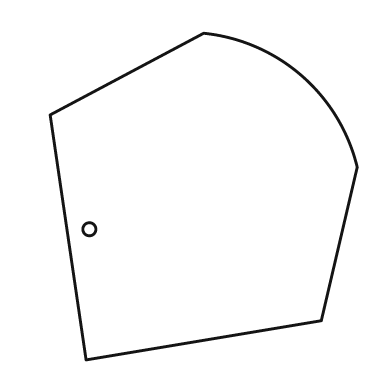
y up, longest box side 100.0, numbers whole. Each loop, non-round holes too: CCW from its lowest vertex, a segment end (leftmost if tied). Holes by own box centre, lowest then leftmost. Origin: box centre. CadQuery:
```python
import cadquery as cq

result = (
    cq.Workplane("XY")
    .moveTo(-36.0, -50.0)
    .lineTo(36.0, -38.0)
    .lineTo(47.0, 9.0)
    .threePointArc((30.0, 37.0), (0.0, 50.0))
    .lineTo(-47.0, 25.0)
    .close()
    .moveTo(-35.0, -10.0)
    .circle(2.0)
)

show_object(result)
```